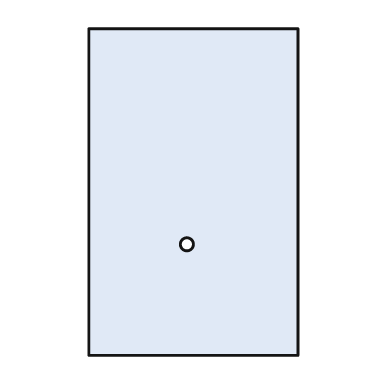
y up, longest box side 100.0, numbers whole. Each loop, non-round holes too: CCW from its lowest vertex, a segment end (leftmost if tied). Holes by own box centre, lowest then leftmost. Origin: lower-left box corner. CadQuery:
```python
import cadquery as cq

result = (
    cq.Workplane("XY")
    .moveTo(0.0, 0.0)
    .lineTo(64.0, 0.0)
    .lineTo(64.0, 100.0)
    .lineTo(0.0, 100.0)
    .close()
    .moveTo(30.0, 34.0)
    .circle(2.0)
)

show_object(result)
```